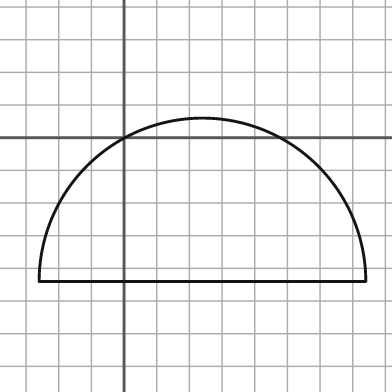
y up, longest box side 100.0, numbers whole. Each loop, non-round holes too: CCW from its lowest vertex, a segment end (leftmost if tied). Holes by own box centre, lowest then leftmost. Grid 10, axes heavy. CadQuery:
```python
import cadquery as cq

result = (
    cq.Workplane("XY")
    .moveTo(-26.0, -44.0)
    .lineTo(74.0, -44.0)
    .threePointArc((24.0, 6.0), (-26.0, -44.0))
    .close()
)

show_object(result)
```